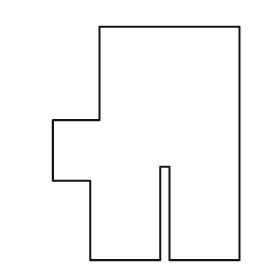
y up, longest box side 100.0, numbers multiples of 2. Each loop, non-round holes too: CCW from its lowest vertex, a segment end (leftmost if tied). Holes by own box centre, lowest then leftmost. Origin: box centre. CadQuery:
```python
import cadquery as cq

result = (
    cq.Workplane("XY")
    .moveTo(-24.0, -50.0)
    .lineTo(6.0, -50.0)
    .lineTo(6.0, -10.0)
    .lineTo(10.0, -10.0)
    .lineTo(10.0, -50.0)
    .lineTo(40.0, -50.0)
    .lineTo(40.0, 50.0)
    .lineTo(-20.0, 50.0)
    .lineTo(-20.0, 10.0)
    .lineTo(-40.0, 10.0)
    .lineTo(-40.0, -16.0)
    .lineTo(-24.0, -16.0)
    .close()
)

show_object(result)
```